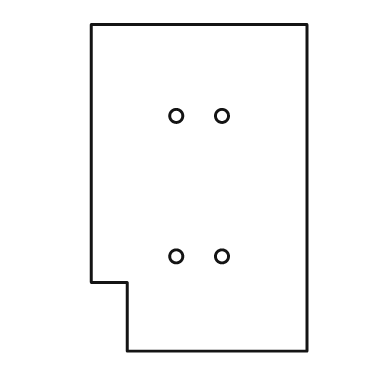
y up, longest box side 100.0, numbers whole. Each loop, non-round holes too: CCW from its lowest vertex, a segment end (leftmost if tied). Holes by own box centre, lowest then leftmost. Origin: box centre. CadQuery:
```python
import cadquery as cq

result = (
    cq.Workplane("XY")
    .moveTo(-22.0, -50.0)
    .lineTo(33.0, -50.0)
    .lineTo(33.0, 50.0)
    .lineTo(-33.0, 50.0)
    .lineTo(-33.0, -29.0)
    .lineTo(-22.0, -29.0)
    .close()
    .moveTo(-7.0, -21.0)
    .circle(2.0)
    .moveTo(7.0, -21.0)
    .circle(2.0)
    .moveTo(-7.0, 22.0)
    .circle(2.0)
    .moveTo(7.0, 22.0)
    .circle(2.0)
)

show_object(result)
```